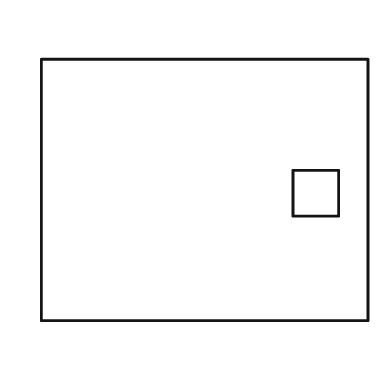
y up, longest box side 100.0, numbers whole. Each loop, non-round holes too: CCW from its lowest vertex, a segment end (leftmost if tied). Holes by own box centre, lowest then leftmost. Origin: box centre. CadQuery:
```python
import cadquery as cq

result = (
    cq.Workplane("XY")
    .moveTo(-50.0, -40.0)
    .lineTo(50.0, -40.0)
    .lineTo(50.0, 40.0)
    .lineTo(-50.0, 40.0)
    .close()
    .moveTo(27.0, -8.0)
    .lineTo(41.0, -8.0)
    .lineTo(41.0, 6.0)
    .lineTo(27.0, 6.0)
    .close()
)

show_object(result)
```